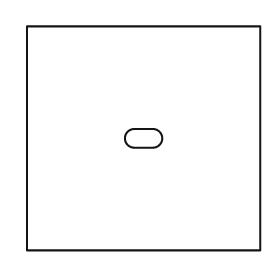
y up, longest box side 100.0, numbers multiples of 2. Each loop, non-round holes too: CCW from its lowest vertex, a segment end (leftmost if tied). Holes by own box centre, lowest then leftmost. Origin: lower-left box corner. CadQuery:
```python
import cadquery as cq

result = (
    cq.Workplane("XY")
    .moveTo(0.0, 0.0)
    .lineTo(100.0, 0.0)
    .lineTo(100.0, 96.0)
    .lineTo(0.0, 96.0)
    .close()
    .moveTo(46.0, 44.0)
    .lineTo(54.0, 44.0)
    .threePointArc((58.0, 48.0), (54.0, 52.0))
    .lineTo(46.0, 52.0)
    .threePointArc((42.0, 48.0), (46.0, 44.0))
    .close()
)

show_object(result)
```